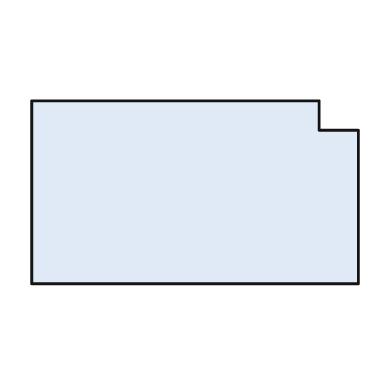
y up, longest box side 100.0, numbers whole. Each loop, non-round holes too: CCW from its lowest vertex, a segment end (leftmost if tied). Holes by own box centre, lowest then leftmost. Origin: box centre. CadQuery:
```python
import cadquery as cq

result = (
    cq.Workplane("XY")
    .moveTo(-50.0, -28.0)
    .lineTo(50.0, -28.0)
    .lineTo(50.0, 19.0)
    .lineTo(38.0, 19.0)
    .lineTo(38.0, 28.0)
    .lineTo(-50.0, 28.0)
    .close()
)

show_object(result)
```